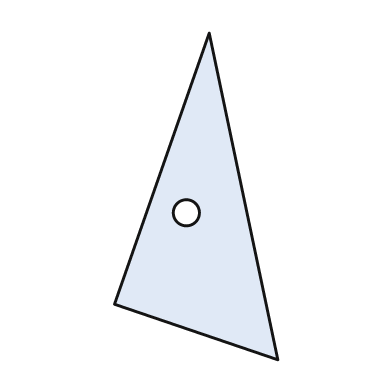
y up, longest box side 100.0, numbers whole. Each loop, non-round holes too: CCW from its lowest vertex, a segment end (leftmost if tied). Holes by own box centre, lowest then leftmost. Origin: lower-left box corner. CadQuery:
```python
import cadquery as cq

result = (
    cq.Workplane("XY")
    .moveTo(50.0, 0.0)
    .lineTo(29.0, 100.0)
    .lineTo(0.0, 17.0)
    .close()
    .moveTo(22.0, 45.0)
    .circle(4.0)
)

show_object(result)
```